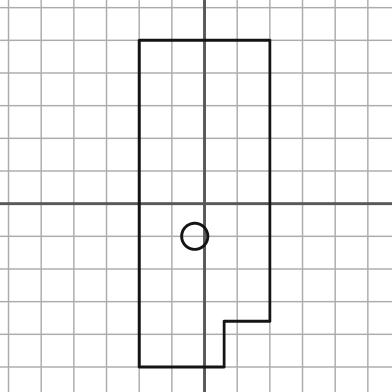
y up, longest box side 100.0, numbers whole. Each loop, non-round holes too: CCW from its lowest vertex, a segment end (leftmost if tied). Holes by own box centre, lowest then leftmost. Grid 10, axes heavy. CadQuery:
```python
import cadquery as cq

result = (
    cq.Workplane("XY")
    .moveTo(-20.0, -50.0)
    .lineTo(6.0, -50.0)
    .lineTo(6.0, -36.0)
    .lineTo(20.0, -36.0)
    .lineTo(20.0, 50.0)
    .lineTo(-20.0, 50.0)
    .close()
    .moveTo(-3.0, -10.0)
    .circle(4.0)
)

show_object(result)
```